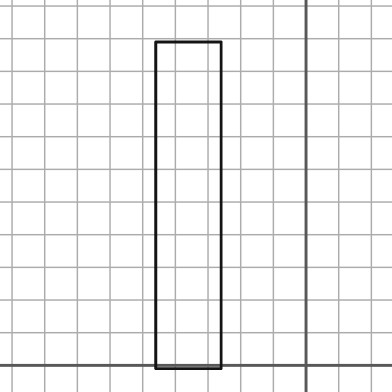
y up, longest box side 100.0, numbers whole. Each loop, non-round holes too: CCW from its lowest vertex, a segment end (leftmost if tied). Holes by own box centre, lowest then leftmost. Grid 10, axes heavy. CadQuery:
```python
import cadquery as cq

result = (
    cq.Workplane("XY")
    .moveTo(-46.0, -1.0)
    .lineTo(-26.0, -1.0)
    .lineTo(-26.0, 99.0)
    .lineTo(-46.0, 99.0)
    .close()
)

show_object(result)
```